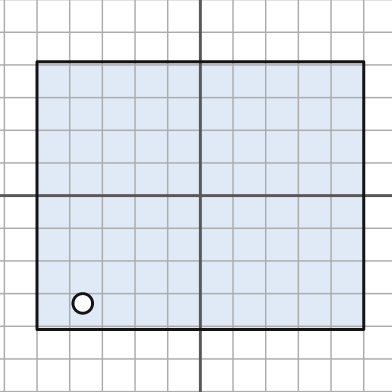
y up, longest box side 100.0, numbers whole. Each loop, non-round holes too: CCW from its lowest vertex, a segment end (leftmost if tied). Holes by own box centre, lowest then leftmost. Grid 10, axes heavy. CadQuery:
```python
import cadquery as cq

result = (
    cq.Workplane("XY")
    .moveTo(-50.0, -41.0)
    .lineTo(50.0, -41.0)
    .lineTo(50.0, 41.0)
    .lineTo(-50.0, 41.0)
    .close()
    .moveTo(-36.0, -33.0)
    .circle(3.0)
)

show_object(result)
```